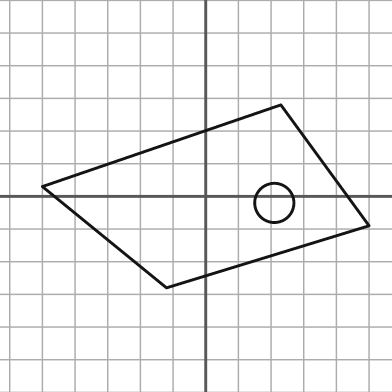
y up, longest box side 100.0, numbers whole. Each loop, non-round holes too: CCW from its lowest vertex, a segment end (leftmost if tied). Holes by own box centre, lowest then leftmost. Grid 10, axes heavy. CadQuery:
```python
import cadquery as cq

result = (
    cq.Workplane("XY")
    .moveTo(-12.0, -28.0)
    .lineTo(50.0, -9.0)
    .lineTo(23.0, 28.0)
    .lineTo(-50.0, 3.0)
    .close()
    .moveTo(21.0, -2.0)
    .circle(6.0)
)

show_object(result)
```